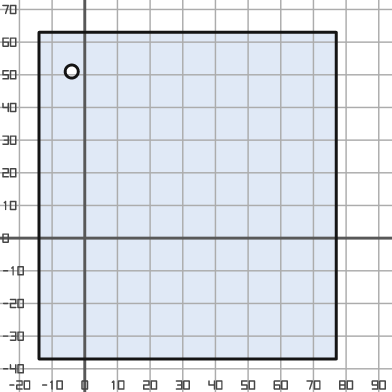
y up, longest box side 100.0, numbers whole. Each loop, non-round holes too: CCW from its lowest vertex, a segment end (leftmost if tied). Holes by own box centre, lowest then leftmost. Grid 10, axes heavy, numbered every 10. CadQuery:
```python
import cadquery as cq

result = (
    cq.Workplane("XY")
    .moveTo(-14.0, -37.0)
    .lineTo(77.0, -37.0)
    .lineTo(77.0, 63.0)
    .lineTo(-14.0, 63.0)
    .close()
    .moveTo(-4.0, 51.0)
    .circle(2.0)
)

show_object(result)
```